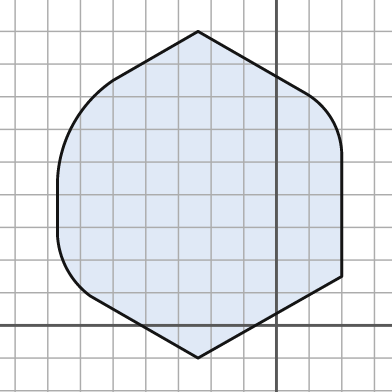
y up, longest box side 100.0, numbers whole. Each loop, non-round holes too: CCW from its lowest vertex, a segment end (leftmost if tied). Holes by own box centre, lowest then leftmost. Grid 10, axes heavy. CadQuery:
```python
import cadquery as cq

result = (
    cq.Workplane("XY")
    .moveTo(-24.0, -10.0)
    .lineTo(20.0, 15.0)
    .lineTo(20.0, 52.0)
    .threePointArc((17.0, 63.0), (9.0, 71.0))
    .lineTo(-24.0, 90.0)
    .lineTo(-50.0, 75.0)
    .threePointArc((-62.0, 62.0), (-67.0, 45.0))
    .lineTo(-67.0, 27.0)
    .threePointArc((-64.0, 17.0), (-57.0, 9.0))
    .close()
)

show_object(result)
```